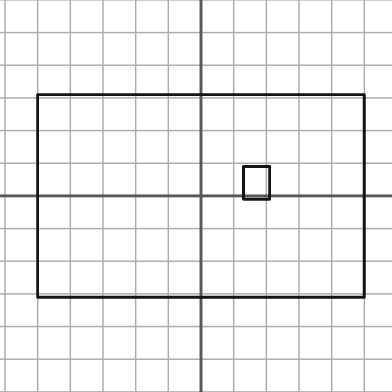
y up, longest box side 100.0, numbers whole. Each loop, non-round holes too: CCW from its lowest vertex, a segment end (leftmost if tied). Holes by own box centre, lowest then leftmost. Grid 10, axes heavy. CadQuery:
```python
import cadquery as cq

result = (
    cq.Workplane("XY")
    .moveTo(-50.0, -31.0)
    .lineTo(50.0, -31.0)
    .lineTo(50.0, 31.0)
    .lineTo(-50.0, 31.0)
    .close()
    .moveTo(13.0, -1.0)
    .lineTo(21.0, -1.0)
    .lineTo(21.0, 9.0)
    .lineTo(13.0, 9.0)
    .close()
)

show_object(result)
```